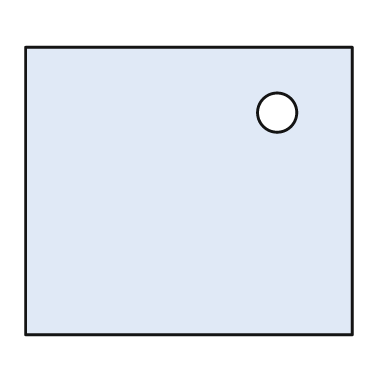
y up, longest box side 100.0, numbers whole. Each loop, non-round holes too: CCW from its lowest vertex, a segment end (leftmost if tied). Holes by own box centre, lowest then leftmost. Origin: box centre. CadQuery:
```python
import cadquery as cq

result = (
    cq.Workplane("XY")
    .moveTo(-50.0, -44.0)
    .lineTo(50.0, -44.0)
    .lineTo(50.0, 44.0)
    .lineTo(-50.0, 44.0)
    .close()
    .moveTo(27.0, 24.0)
    .circle(6.0)
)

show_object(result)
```